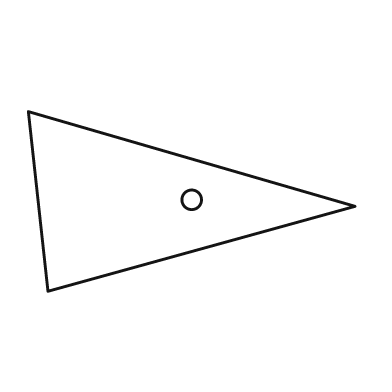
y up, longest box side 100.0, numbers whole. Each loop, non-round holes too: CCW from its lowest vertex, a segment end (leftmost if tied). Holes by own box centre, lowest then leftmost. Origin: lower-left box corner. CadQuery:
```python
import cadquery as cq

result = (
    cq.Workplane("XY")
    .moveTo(6.0, 0.0)
    .lineTo(100.0, 26.0)
    .lineTo(0.0, 55.0)
    .close()
    .moveTo(50.0, 28.0)
    .circle(3.0)
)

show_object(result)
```